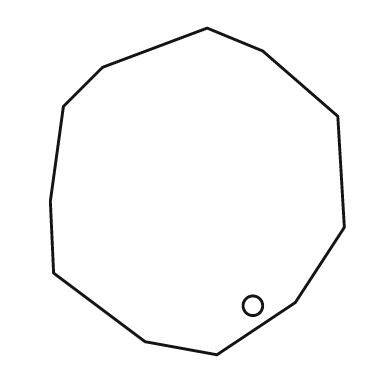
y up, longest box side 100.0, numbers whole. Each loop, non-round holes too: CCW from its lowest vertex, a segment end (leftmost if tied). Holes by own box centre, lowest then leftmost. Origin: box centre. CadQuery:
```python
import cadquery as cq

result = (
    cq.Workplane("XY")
    .moveTo(6.0, -50.0)
    .lineTo(30.0, -34.0)
    .lineTo(45.0, -11.0)
    .lineTo(43.0, 23.0)
    .lineTo(20.0, 43.0)
    .lineTo(3.0, 50.0)
    .lineTo(-29.0, 38.0)
    .lineTo(-41.0, 26.0)
    .lineTo(-45.0, -3.0)
    .lineTo(-44.0, -25.0)
    .lineTo(-16.0, -46.0)
    .close()
    .moveTo(17.0, -35.0)
    .circle(3.0)
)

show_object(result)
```